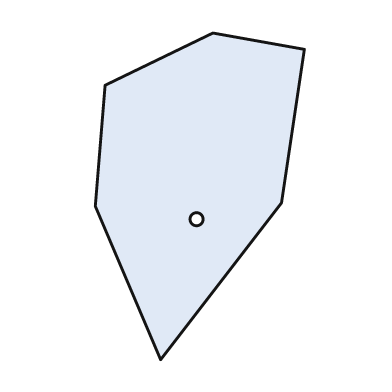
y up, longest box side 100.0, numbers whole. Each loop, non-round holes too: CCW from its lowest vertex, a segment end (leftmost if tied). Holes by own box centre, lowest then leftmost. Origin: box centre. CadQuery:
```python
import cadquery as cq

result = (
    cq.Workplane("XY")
    .moveTo(-12.0, -50.0)
    .lineTo(25.0, -2.0)
    .lineTo(32.0, 45.0)
    .lineTo(4.0, 50.0)
    .lineTo(-29.0, 34.0)
    .lineTo(-32.0, -3.0)
    .close()
    .moveTo(-1.0, -7.0)
    .circle(2.0)
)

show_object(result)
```